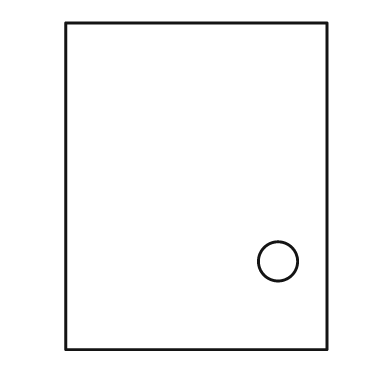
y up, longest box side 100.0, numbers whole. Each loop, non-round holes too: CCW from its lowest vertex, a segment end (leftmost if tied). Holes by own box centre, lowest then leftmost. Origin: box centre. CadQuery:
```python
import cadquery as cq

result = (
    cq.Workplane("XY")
    .moveTo(-40.0, -50.0)
    .lineTo(40.0, -50.0)
    .lineTo(40.0, 50.0)
    .lineTo(-40.0, 50.0)
    .close()
    .moveTo(25.0, -23.0)
    .circle(6.0)
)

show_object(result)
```